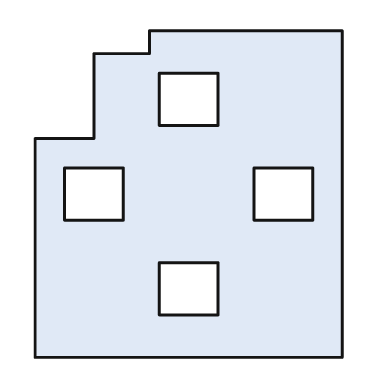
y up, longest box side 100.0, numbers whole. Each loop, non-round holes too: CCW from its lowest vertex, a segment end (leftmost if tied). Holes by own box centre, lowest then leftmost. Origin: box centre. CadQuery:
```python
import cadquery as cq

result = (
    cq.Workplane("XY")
    .moveTo(-47.0, -50.0)
    .lineTo(47.0, -50.0)
    .lineTo(47.0, 50.0)
    .lineTo(-12.0, 50.0)
    .lineTo(-12.0, 43.0)
    .lineTo(-29.0, 43.0)
    .lineTo(-29.0, 17.0)
    .lineTo(-47.0, 17.0)
    .close()
    .moveTo(-9.0, -37.0)
    .lineTo(9.0, -37.0)
    .lineTo(9.0, -21.0)
    .lineTo(-9.0, -21.0)
    .close()
    .moveTo(-38.0, -8.0)
    .lineTo(-20.0, -8.0)
    .lineTo(-20.0, 8.0)
    .lineTo(-38.0, 8.0)
    .close()
    .moveTo(20.0, -8.0)
    .lineTo(38.0, -8.0)
    .lineTo(38.0, 8.0)
    .lineTo(20.0, 8.0)
    .close()
    .moveTo(-9.0, 21.0)
    .lineTo(9.0, 21.0)
    .lineTo(9.0, 37.0)
    .lineTo(-9.0, 37.0)
    .close()
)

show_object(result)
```